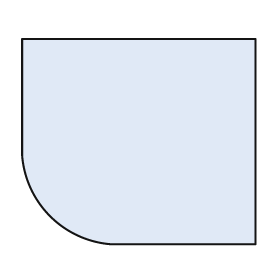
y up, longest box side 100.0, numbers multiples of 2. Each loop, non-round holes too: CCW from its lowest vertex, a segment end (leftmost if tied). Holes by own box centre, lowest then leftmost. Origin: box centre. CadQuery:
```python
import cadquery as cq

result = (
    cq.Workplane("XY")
    .moveTo(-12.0, -44.0)
    .lineTo(50.0, -44.0)
    .lineTo(50.0, 44.0)
    .lineTo(-50.0, 44.0)
    .lineTo(-50.0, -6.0)
    .threePointArc((-38.0, -32.0), (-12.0, -44.0))
    .close()
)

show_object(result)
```